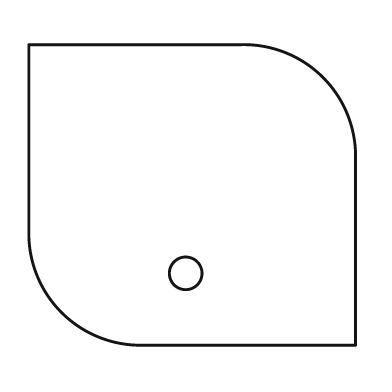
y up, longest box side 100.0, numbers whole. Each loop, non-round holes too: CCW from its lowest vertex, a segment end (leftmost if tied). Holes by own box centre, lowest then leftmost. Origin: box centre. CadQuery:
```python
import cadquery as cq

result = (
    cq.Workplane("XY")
    .moveTo(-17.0, -46.0)
    .lineTo(50.0, -46.0)
    .lineTo(50.0, 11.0)
    .threePointArc((40.0, 36.0), (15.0, 46.0))
    .lineTo(-50.0, 46.0)
    .lineTo(-50.0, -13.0)
    .threePointArc((-40.0, -36.0), (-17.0, -46.0))
    .close()
    .moveTo(-2.0, -24.0)
    .circle(5.0)
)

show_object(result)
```